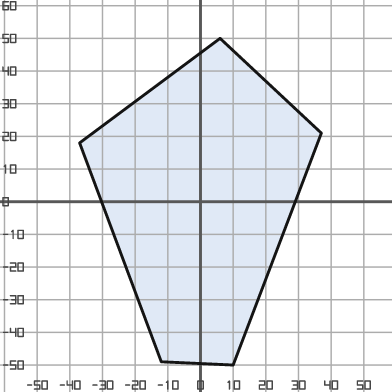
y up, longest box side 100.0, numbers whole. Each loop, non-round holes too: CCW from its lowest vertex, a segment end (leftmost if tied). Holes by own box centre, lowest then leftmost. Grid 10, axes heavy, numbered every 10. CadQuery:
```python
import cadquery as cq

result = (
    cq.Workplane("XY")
    .moveTo(10.0, -50.0)
    .lineTo(37.0, 21.0)
    .lineTo(6.0, 50.0)
    .lineTo(-37.0, 18.0)
    .lineTo(-12.0, -49.0)
    .close()
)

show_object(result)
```